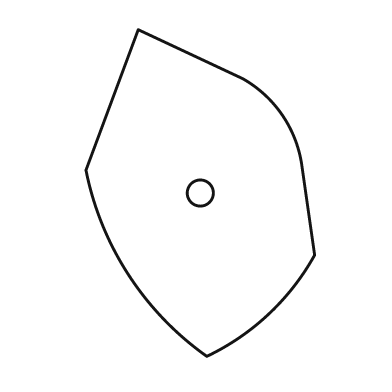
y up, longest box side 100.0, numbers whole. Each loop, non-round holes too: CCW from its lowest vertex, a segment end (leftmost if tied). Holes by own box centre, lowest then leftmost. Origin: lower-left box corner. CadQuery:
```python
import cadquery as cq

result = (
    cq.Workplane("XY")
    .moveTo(37.0, 0.0)
    .threePointArc((56.0, 13.0), (70.0, 31.0))
    .lineTo(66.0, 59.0)
    .threePointArc((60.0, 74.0), (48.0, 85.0))
    .lineTo(16.0, 100.0)
    .lineTo(0.0, 57.0)
    .threePointArc((13.0, 25.0), (37.0, 0.0))
    .close()
    .moveTo(35.0, 50.0)
    .circle(4.0)
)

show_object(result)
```